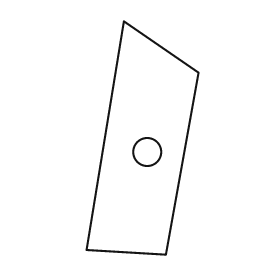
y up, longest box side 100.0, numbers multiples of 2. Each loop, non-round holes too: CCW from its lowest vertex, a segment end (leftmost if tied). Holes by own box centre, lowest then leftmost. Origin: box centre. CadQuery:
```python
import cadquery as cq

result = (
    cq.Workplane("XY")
    .moveTo(10.0, -50.0)
    .lineTo(24.0, 28.0)
    .lineTo(-8.0, 50.0)
    .lineTo(-24.0, -48.0)
    .close()
    .moveTo(2.0, -6.0)
    .circle(6.0)
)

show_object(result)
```